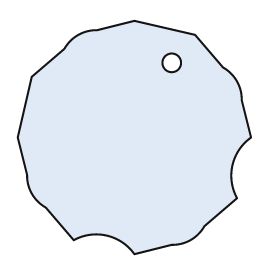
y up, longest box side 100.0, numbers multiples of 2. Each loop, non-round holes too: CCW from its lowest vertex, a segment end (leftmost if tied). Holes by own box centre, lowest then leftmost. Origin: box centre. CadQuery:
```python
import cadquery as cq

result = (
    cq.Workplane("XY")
    .moveTo(0.0, -50.0)
    .lineTo(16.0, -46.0)
    .threePointArc((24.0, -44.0), (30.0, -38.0))
    .lineTo(44.0, -26.0)
    .threePointArc((42.0, -12.0), (50.0, 0.0))
    .lineTo(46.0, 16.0)
    .threePointArc((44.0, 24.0), (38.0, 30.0))
    .lineTo(26.0, 44.0)
    .lineTo(0.0, 50.0)
    .lineTo(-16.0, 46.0)
    .threePointArc((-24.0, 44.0), (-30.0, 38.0))
    .lineTo(-44.0, 26.0)
    .lineTo(-50.0, 0.0)
    .lineTo(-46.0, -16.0)
    .threePointArc((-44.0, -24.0), (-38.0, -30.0))
    .lineTo(-26.0, -44.0)
    .threePointArc((-12.0, -42.0), (0.0, -50.0))
    .close()
    .moveTo(16.0, 32.0)
    .circle(4.0)
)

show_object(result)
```